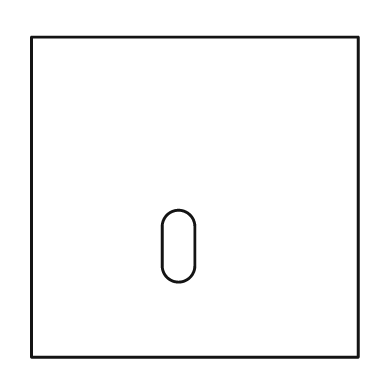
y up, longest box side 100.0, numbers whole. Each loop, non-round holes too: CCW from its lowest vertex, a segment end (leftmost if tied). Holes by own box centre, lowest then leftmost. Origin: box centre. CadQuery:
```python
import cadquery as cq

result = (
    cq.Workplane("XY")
    .moveTo(-50.0, -49.0)
    .lineTo(50.0, -49.0)
    .lineTo(50.0, 49.0)
    .lineTo(-50.0, 49.0)
    .close()
    .moveTo(-10.0, -21.0)
    .threePointArc((-5.0, -26.0), (0.0, -21.0))
    .lineTo(0.0, -9.0)
    .threePointArc((-5.0, -4.0), (-10.0, -9.0))
    .close()
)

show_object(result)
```